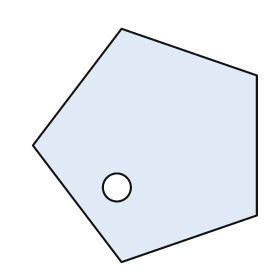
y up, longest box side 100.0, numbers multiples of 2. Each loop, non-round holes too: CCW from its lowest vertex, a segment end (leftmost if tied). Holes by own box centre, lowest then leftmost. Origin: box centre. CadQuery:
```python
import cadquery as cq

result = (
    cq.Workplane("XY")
    .moveTo(-10.0, -50.0)
    .lineTo(48.0, -30.0)
    .lineTo(48.0, 30.0)
    .lineTo(-10.0, 50.0)
    .lineTo(-48.0, 0.0)
    .close()
    .moveTo(-12.0, -18.0)
    .circle(6.0)
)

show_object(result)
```